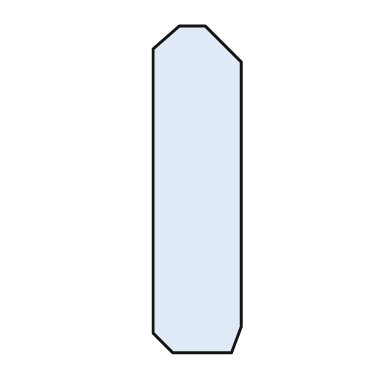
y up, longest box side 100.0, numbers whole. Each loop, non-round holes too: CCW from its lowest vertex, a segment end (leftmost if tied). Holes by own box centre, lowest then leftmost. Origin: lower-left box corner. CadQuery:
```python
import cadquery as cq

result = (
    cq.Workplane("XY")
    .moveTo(6.0, 0.0)
    .lineTo(24.0, 0.0)
    .lineTo(27.0, 8.0)
    .lineTo(27.0, 89.0)
    .lineTo(16.0, 100.0)
    .lineTo(8.0, 100.0)
    .lineTo(0.0, 93.0)
    .lineTo(0.0, 6.0)
    .close()
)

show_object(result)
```